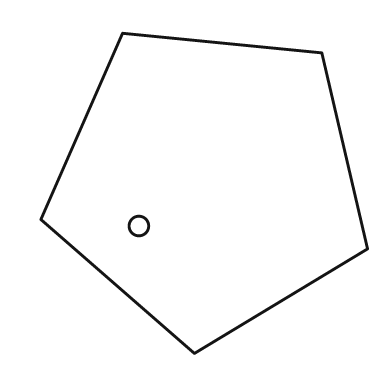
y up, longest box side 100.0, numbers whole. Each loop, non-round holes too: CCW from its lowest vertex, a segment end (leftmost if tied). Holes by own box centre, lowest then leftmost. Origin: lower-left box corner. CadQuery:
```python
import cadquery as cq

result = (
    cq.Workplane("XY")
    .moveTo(47.0, 0.0)
    .lineTo(100.0, 32.0)
    .lineTo(86.0, 92.0)
    .lineTo(25.0, 98.0)
    .lineTo(0.0, 41.0)
    .close()
    .moveTo(30.0, 39.0)
    .circle(3.0)
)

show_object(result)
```